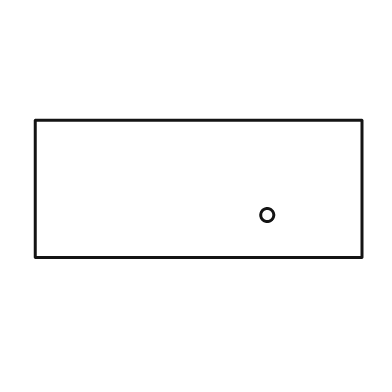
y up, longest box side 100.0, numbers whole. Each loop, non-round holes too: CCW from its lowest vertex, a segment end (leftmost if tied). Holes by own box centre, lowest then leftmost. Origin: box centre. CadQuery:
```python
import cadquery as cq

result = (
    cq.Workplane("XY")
    .moveTo(-50.0, -21.0)
    .lineTo(50.0, -21.0)
    .lineTo(50.0, 21.0)
    .lineTo(-50.0, 21.0)
    .close()
    .moveTo(21.0, -8.0)
    .circle(2.0)
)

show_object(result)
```